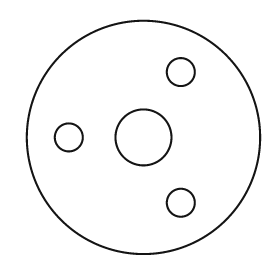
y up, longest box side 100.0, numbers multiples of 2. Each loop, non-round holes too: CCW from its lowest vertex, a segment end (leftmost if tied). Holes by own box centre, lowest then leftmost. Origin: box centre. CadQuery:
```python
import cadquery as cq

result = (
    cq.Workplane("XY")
    .moveTo(0.0, 0.0)
    .circle(50.0)
    .moveTo(16.0, -28.0)
    .circle(6.0)
    .moveTo(-32.0, 0.0)
    .circle(6.0)
    .moveTo(0.0, 0.0)
    .circle(12.0)
    .moveTo(16.0, 28.0)
    .circle(6.0)
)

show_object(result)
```